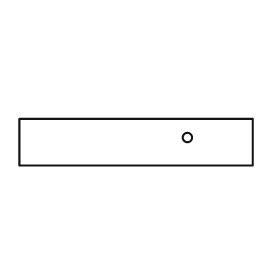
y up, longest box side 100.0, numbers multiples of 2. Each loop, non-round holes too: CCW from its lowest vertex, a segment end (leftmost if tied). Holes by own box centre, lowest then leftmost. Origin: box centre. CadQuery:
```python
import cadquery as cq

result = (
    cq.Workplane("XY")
    .moveTo(-50.0, -10.0)
    .lineTo(50.0, -10.0)
    .lineTo(50.0, 10.0)
    .lineTo(-50.0, 10.0)
    .close()
    .moveTo(22.0, 2.0)
    .circle(2.0)
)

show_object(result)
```